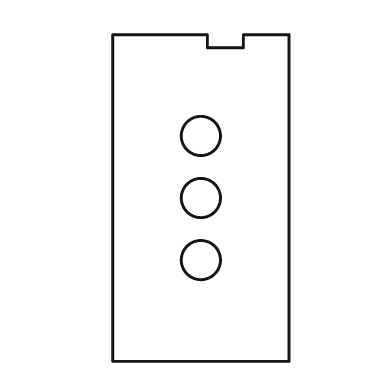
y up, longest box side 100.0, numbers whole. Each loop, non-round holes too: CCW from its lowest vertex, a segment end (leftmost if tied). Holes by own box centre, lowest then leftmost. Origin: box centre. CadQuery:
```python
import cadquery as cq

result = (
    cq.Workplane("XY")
    .moveTo(-27.0, -50.0)
    .lineTo(27.0, -50.0)
    .lineTo(27.0, 50.0)
    .lineTo(13.0, 50.0)
    .lineTo(13.0, 46.0)
    .lineTo(2.0, 46.0)
    .lineTo(2.0, 50.0)
    .lineTo(-27.0, 50.0)
    .close()
    .moveTo(0.0, -19.0)
    .circle(6.0)
    .moveTo(0.0, 0.0)
    .circle(6.0)
    .moveTo(0.0, 19.0)
    .circle(6.0)
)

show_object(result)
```